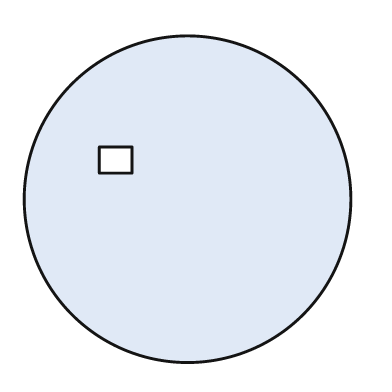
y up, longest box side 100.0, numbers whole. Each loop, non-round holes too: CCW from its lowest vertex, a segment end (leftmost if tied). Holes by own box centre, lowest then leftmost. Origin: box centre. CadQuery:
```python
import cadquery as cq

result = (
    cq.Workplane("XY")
    .moveTo(0.0, 0.0)
    .circle(50.0)
    .moveTo(-27.0, 8.0)
    .lineTo(-17.0, 8.0)
    .lineTo(-17.0, 16.0)
    .lineTo(-27.0, 16.0)
    .close()
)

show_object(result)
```